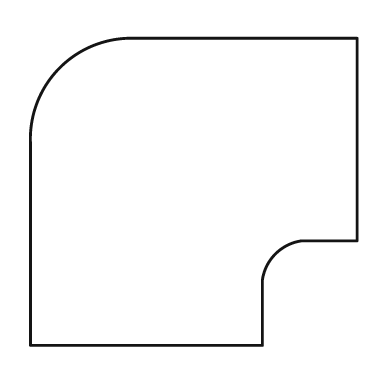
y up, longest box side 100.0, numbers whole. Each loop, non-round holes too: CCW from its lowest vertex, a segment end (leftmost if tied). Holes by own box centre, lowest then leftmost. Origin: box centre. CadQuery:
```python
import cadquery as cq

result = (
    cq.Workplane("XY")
    .moveTo(-50.0, -47.0)
    .lineTo(21.0, -47.0)
    .lineTo(21.0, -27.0)
    .threePointArc((25.0, -19.0), (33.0, -15.0))
    .lineTo(50.0, -15.0)
    .lineTo(50.0, 47.0)
    .lineTo(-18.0, 47.0)
    .threePointArc((-41.0, 38.0), (-50.0, 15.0))
    .close()
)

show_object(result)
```